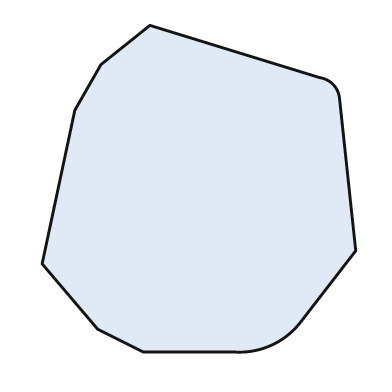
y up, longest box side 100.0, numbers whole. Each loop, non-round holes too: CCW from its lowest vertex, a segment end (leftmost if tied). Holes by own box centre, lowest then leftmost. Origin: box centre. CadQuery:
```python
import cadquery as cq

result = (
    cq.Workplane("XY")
    .moveTo(-17.0, -50.0)
    .lineTo(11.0, -50.0)
    .threePointArc((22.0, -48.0), (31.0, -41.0))
    .lineTo(48.0, -19.0)
    .lineTo(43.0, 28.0)
    .threePointArc((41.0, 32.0), (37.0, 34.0))
    .lineTo(-15.0, 50.0)
    .lineTo(-30.0, 38.0)
    .lineTo(-38.0, 24.0)
    .lineTo(-48.0, -23.0)
    .lineTo(-31.0, -43.0)
    .close()
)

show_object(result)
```